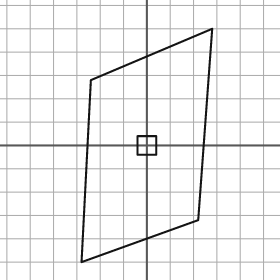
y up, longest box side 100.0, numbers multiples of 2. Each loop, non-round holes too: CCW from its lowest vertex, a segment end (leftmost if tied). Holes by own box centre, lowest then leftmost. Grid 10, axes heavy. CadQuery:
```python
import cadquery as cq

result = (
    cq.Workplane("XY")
    .moveTo(-28.0, -50.0)
    .lineTo(22.0, -32.0)
    .lineTo(28.0, 50.0)
    .lineTo(-24.0, 28.0)
    .close()
    .moveTo(-4.0, -4.0)
    .lineTo(4.0, -4.0)
    .lineTo(4.0, 4.0)
    .lineTo(-4.0, 4.0)
    .close()
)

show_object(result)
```